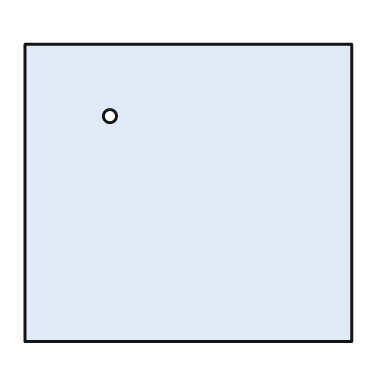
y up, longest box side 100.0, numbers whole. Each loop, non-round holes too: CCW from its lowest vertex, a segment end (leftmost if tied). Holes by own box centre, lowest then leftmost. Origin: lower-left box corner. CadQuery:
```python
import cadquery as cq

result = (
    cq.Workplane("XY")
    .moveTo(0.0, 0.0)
    .lineTo(100.0, 0.0)
    .lineTo(100.0, 91.0)
    .lineTo(0.0, 91.0)
    .close()
    .moveTo(26.0, 69.0)
    .circle(2.0)
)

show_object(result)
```